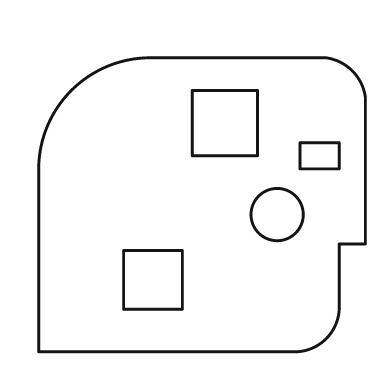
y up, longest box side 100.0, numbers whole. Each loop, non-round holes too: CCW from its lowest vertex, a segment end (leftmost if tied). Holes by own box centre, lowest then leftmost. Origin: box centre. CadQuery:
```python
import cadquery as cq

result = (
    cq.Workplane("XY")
    .moveTo(-50.0, -45.0)
    .lineTo(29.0, -45.0)
    .threePointArc((38.0, -41.0), (42.0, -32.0))
    .lineTo(42.0, -12.0)
    .lineTo(50.0, -12.0)
    .lineTo(50.0, 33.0)
    .threePointArc((46.0, 41.0), (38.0, 45.0))
    .lineTo(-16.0, 45.0)
    .threePointArc((-40.0, 35.0), (-50.0, 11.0))
    .close()
    .moveTo(-24.0, -32.0)
    .lineTo(-6.0, -32.0)
    .lineTo(-6.0, -14.0)
    .lineTo(-24.0, -14.0)
    .close()
    .moveTo(23.0, -3.0)
    .circle(8.0)
    .moveTo(30.0, 11.0)
    .lineTo(42.0, 11.0)
    .lineTo(42.0, 19.0)
    .lineTo(30.0, 19.0)
    .close()
    .moveTo(-3.0, 15.0)
    .lineTo(17.0, 15.0)
    .lineTo(17.0, 35.0)
    .lineTo(-3.0, 35.0)
    .close()
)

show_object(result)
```